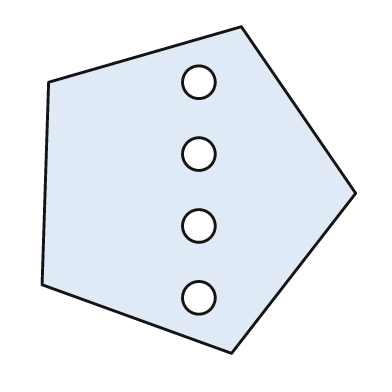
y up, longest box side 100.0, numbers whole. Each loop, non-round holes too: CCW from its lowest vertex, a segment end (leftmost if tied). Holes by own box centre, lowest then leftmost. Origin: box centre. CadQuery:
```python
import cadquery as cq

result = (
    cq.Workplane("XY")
    .moveTo(10.0, -50.0)
    .lineTo(48.0, -1.0)
    .lineTo(13.0, 50.0)
    .lineTo(-46.0, 33.0)
    .lineTo(-48.0, -29.0)
    .close()
    .moveTo(0.0, -33.0)
    .circle(5.0)
    .moveTo(0.0, -11.0)
    .circle(5.0)
    .moveTo(0.0, 11.0)
    .circle(5.0)
    .moveTo(0.0, 33.0)
    .circle(5.0)
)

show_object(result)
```